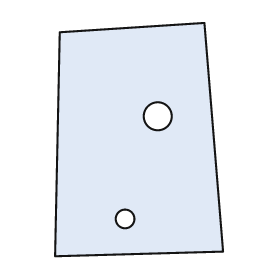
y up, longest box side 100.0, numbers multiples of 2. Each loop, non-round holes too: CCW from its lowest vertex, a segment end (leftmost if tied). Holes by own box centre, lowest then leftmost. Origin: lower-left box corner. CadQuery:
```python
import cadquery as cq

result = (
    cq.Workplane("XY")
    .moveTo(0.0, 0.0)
    .lineTo(72.0, 2.0)
    .lineTo(64.0, 100.0)
    .lineTo(2.0, 96.0)
    .close()
    .moveTo(30.0, 16.0)
    .circle(4.0)
    .moveTo(44.0, 60.0)
    .circle(6.0)
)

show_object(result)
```